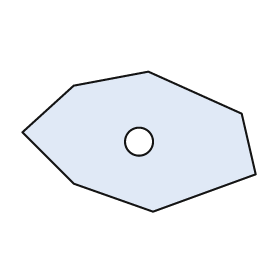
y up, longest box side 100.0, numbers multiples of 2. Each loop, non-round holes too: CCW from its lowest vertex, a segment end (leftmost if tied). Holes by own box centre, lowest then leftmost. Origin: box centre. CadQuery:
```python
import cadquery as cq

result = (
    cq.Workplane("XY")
    .moveTo(6.0, -30.0)
    .lineTo(50.0, -14.0)
    .lineTo(44.0, 12.0)
    .lineTo(4.0, 30.0)
    .lineTo(-28.0, 24.0)
    .lineTo(-50.0, 4.0)
    .lineTo(-28.0, -18.0)
    .close()
    .moveTo(0.0, 0.0)
    .circle(6.0)
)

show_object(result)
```